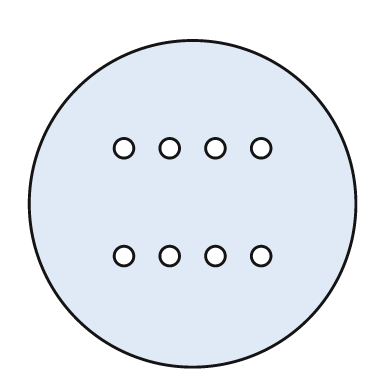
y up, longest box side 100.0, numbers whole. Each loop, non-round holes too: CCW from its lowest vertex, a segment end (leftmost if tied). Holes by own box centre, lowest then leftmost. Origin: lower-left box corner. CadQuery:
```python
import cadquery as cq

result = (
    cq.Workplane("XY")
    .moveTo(50.0, 50.0)
    .circle(50.0)
    .moveTo(29.0, 34.0)
    .circle(3.0)
    .moveTo(43.0, 34.0)
    .circle(3.0)
    .moveTo(57.0, 34.0)
    .circle(3.0)
    .moveTo(71.0, 34.0)
    .circle(3.0)
    .moveTo(29.0, 67.0)
    .circle(3.0)
    .moveTo(43.0, 67.0)
    .circle(3.0)
    .moveTo(57.0, 67.0)
    .circle(3.0)
    .moveTo(71.0, 67.0)
    .circle(3.0)
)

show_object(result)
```